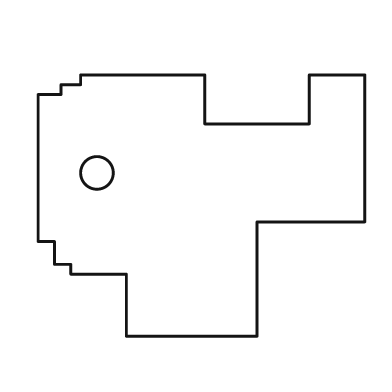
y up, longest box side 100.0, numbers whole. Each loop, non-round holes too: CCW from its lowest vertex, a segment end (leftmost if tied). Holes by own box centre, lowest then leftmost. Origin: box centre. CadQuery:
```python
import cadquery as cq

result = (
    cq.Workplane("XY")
    .moveTo(-23.0, -40.0)
    .lineTo(17.0, -40.0)
    .lineTo(17.0, -5.0)
    .lineTo(50.0, -5.0)
    .lineTo(50.0, 40.0)
    .lineTo(33.0, 40.0)
    .lineTo(33.0, 25.0)
    .lineTo(1.0, 25.0)
    .lineTo(1.0, 40.0)
    .lineTo(-37.0, 40.0)
    .lineTo(-37.0, 37.0)
    .lineTo(-43.0, 37.0)
    .lineTo(-43.0, 34.0)
    .lineTo(-50.0, 34.0)
    .lineTo(-50.0, -11.0)
    .lineTo(-45.0, -11.0)
    .lineTo(-45.0, -18.0)
    .lineTo(-40.0, -18.0)
    .lineTo(-40.0, -21.0)
    .lineTo(-23.0, -21.0)
    .close()
    .moveTo(-32.0, 10.0)
    .circle(5.0)
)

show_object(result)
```